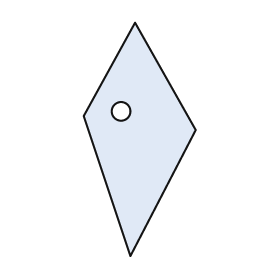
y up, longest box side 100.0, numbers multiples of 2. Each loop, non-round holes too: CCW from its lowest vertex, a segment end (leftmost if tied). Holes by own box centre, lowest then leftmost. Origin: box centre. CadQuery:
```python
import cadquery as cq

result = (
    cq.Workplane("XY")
    .moveTo(-4.0, -50.0)
    .lineTo(24.0, 4.0)
    .lineTo(-2.0, 50.0)
    .lineTo(-24.0, 10.0)
    .close()
    .moveTo(-8.0, 12.0)
    .circle(4.0)
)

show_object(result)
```